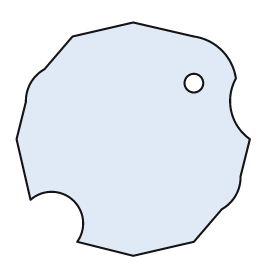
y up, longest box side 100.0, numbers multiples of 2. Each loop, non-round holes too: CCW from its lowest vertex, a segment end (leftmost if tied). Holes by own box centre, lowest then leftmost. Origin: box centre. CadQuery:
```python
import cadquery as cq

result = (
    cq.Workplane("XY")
    .moveTo(0.0, -50.0)
    .lineTo(26.0, -44.0)
    .lineTo(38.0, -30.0)
    .threePointArc((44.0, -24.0), (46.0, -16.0))
    .lineTo(50.0, 0.0)
    .threePointArc((42.0, 12.0), (44.0, 26.0))
    .threePointArc((38.0, 38.0), (26.0, 44.0))
    .lineTo(0.0, 50.0)
    .lineTo(-26.0, 44.0)
    .lineTo(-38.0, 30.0)
    .threePointArc((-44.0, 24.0), (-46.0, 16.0))
    .lineTo(-50.0, 0.0)
    .lineTo(-44.0, -26.0)
    .threePointArc((-26.0, -26.0), (-24.0, -44.0))
    .close()
    .moveTo(26.0, 24.0)
    .circle(4.0)
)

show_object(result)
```